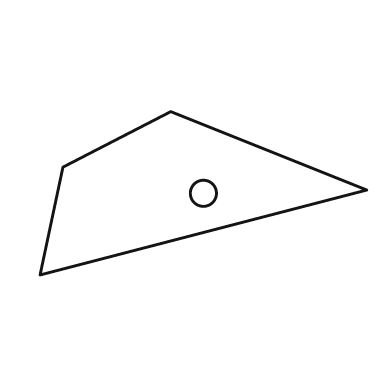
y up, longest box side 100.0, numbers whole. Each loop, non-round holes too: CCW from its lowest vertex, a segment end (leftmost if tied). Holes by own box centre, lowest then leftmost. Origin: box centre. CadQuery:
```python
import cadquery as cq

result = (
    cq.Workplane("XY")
    .moveTo(-50.0, -25.0)
    .lineTo(50.0, 1.0)
    .lineTo(-10.0, 25.0)
    .lineTo(-43.0, 8.0)
    .close()
    .moveTo(0.0, 0.0)
    .circle(4.0)
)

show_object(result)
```